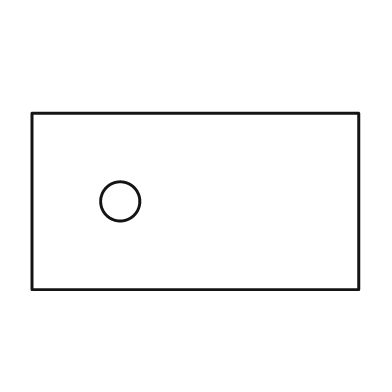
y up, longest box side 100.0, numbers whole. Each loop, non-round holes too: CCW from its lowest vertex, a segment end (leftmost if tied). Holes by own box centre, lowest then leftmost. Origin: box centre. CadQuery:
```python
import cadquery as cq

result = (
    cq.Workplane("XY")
    .moveTo(-50.0, -27.0)
    .lineTo(50.0, -27.0)
    .lineTo(50.0, 27.0)
    .lineTo(-50.0, 27.0)
    .close()
    .moveTo(-23.0, 0.0)
    .circle(6.0)
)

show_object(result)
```